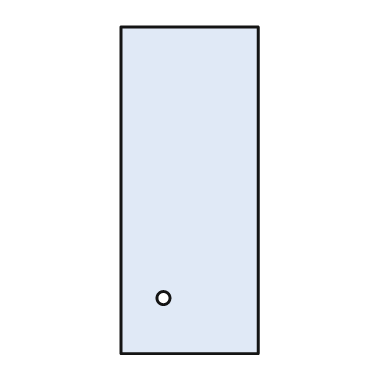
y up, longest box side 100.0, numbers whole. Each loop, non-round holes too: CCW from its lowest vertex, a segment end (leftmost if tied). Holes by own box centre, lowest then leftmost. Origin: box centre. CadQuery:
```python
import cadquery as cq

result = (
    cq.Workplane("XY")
    .moveTo(-21.0, -50.0)
    .lineTo(21.0, -50.0)
    .lineTo(21.0, 50.0)
    .lineTo(-21.0, 50.0)
    .close()
    .moveTo(-8.0, -33.0)
    .circle(2.0)
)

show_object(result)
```